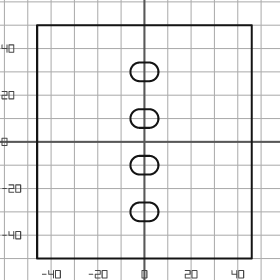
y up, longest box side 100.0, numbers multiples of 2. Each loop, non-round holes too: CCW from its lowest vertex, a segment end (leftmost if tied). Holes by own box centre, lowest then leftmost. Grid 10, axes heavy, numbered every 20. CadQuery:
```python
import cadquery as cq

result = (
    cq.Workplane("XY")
    .moveTo(-46.0, -50.0)
    .lineTo(46.0, -50.0)
    .lineTo(46.0, 50.0)
    .lineTo(-46.0, 50.0)
    .close()
    .moveTo(-2.0, -34.0)
    .lineTo(2.0, -34.0)
    .threePointArc((6.0, -30.0), (2.0, -26.0))
    .lineTo(-2.0, -26.0)
    .threePointArc((-6.0, -30.0), (-2.0, -34.0))
    .close()
    .moveTo(-2.0, -14.0)
    .lineTo(2.0, -14.0)
    .threePointArc((6.0, -10.0), (2.0, -6.0))
    .lineTo(-2.0, -6.0)
    .threePointArc((-6.0, -10.0), (-2.0, -14.0))
    .close()
    .moveTo(-2.0, 6.0)
    .lineTo(2.0, 6.0)
    .threePointArc((6.0, 10.0), (2.0, 14.0))
    .lineTo(-2.0, 14.0)
    .threePointArc((-6.0, 10.0), (-2.0, 6.0))
    .close()
    .moveTo(-2.0, 26.0)
    .lineTo(2.0, 26.0)
    .threePointArc((6.0, 30.0), (2.0, 34.0))
    .lineTo(-2.0, 34.0)
    .threePointArc((-6.0, 30.0), (-2.0, 26.0))
    .close()
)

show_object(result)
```